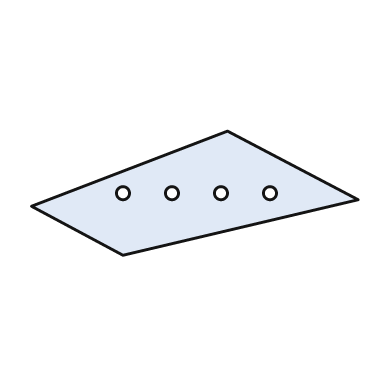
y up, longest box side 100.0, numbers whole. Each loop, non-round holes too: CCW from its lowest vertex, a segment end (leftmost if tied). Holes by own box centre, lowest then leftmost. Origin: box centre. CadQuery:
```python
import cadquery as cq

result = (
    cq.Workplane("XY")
    .moveTo(-22.0, -19.0)
    .lineTo(50.0, -2.0)
    .lineTo(10.0, 19.0)
    .lineTo(-50.0, -4.0)
    .close()
    .moveTo(-22.0, 0.0)
    .circle(2.0)
    .moveTo(-7.0, 0.0)
    .circle(2.0)
    .moveTo(8.0, 0.0)
    .circle(2.0)
    .moveTo(23.0, 0.0)
    .circle(2.0)
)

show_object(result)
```